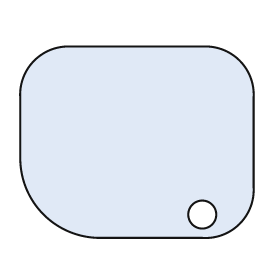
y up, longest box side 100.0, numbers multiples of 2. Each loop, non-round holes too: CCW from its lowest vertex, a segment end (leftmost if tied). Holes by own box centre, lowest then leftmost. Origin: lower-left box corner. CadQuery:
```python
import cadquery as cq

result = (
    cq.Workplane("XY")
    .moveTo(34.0, 0.0)
    .lineTo(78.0, 0.0)
    .threePointArc((94.0, 6.0), (100.0, 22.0))
    .lineTo(100.0, 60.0)
    .threePointArc((94.0, 76.0), (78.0, 82.0))
    .lineTo(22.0, 82.0)
    .threePointArc((6.0, 76.0), (0.0, 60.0))
    .lineTo(0.0, 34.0)
    .threePointArc((10.0, 10.0), (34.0, 0.0))
    .close()
    .moveTo(78.0, 10.0)
    .circle(6.0)
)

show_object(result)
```